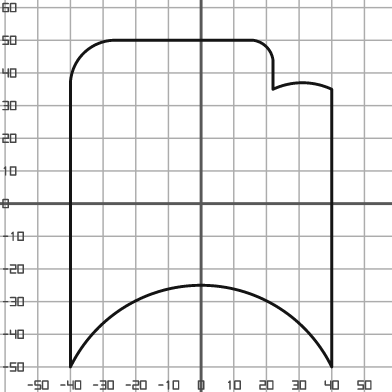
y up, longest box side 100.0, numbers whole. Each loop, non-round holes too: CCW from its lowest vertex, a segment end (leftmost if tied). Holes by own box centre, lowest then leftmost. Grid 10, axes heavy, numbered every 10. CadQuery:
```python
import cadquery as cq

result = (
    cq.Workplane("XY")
    .moveTo(-40.0, -50.0)
    .threePointArc((0.0, -25.0), (40.0, -50.0))
    .lineTo(40.0, 35.0)
    .threePointArc((31.0, 37.0), (22.0, 35.0))
    .lineTo(22.0, 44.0)
    .threePointArc((20.0, 48.0), (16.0, 50.0))
    .lineTo(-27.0, 50.0)
    .threePointArc((-36.0, 46.0), (-40.0, 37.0))
    .close()
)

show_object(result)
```